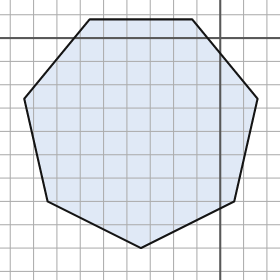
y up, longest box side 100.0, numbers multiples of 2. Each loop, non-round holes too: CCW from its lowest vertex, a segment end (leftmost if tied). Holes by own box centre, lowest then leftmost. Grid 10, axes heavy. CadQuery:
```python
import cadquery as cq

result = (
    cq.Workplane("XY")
    .moveTo(-34.0, -90.0)
    .lineTo(6.0, -70.0)
    .lineTo(16.0, -26.0)
    .lineTo(-12.0, 8.0)
    .lineTo(-56.0, 8.0)
    .lineTo(-84.0, -26.0)
    .lineTo(-74.0, -70.0)
    .close()
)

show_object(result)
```